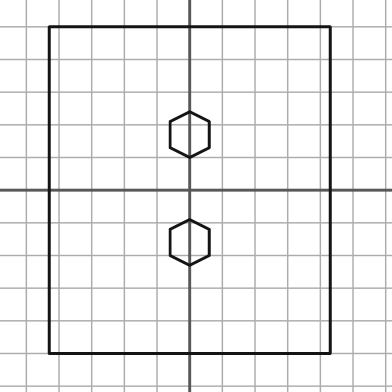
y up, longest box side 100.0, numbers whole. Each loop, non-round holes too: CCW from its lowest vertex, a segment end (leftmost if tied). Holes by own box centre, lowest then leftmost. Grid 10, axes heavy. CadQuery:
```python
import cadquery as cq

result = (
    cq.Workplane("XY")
    .moveTo(-43.0, -50.0)
    .lineTo(43.0, -50.0)
    .lineTo(43.0, 50.0)
    .lineTo(-43.0, 50.0)
    .close()
    .moveTo(0.0, -23.0)
    .lineTo(6.0, -20.0)
    .lineTo(6.0, -12.0)
    .lineTo(0.0, -9.0)
    .lineTo(-6.0, -12.0)
    .lineTo(-6.0, -20.0)
    .close()
    .moveTo(0.0, 10.0)
    .lineTo(6.0, 13.0)
    .lineTo(6.0, 21.0)
    .lineTo(0.0, 24.0)
    .lineTo(-6.0, 21.0)
    .lineTo(-6.0, 13.0)
    .close()
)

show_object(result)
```